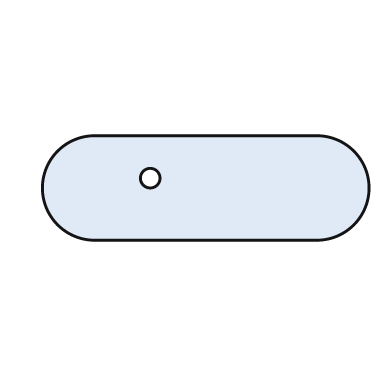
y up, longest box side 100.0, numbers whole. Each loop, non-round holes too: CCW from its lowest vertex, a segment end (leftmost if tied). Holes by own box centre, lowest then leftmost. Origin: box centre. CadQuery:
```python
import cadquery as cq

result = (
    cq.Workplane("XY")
    .moveTo(-34.0, -16.0)
    .lineTo(34.0, -16.0)
    .threePointArc((50.0, 0.0), (34.0, 16.0))
    .lineTo(-34.0, 16.0)
    .threePointArc((-50.0, 0.0), (-34.0, -16.0))
    .close()
    .moveTo(-17.0, 3.0)
    .circle(3.0)
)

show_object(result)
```